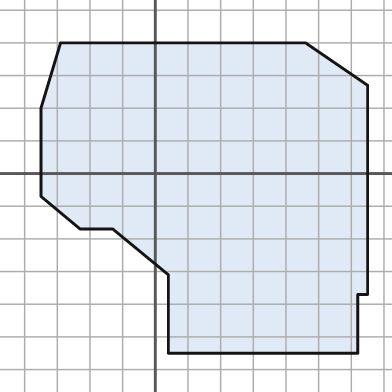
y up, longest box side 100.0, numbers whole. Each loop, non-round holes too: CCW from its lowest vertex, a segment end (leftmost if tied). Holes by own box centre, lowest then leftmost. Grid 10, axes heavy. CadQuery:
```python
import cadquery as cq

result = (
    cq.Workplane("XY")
    .moveTo(4.0, -55.0)
    .lineTo(62.0, -55.0)
    .lineTo(62.0, -37.0)
    .lineTo(65.0, -37.0)
    .lineTo(65.0, 27.0)
    .lineTo(46.0, 40.0)
    .lineTo(-29.0, 40.0)
    .lineTo(-35.0, 20.0)
    .lineTo(-35.0, -7.0)
    .lineTo(-23.0, -17.0)
    .lineTo(-13.0, -17.0)
    .lineTo(4.0, -31.0)
    .close()
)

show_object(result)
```